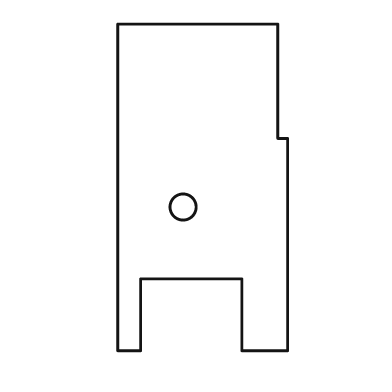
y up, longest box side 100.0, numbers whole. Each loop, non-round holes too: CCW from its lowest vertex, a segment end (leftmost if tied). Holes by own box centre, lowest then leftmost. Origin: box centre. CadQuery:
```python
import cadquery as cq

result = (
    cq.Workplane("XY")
    .moveTo(-26.0, -50.0)
    .lineTo(-19.0, -50.0)
    .lineTo(-19.0, -28.0)
    .lineTo(12.0, -28.0)
    .lineTo(12.0, -50.0)
    .lineTo(26.0, -50.0)
    .lineTo(26.0, 15.0)
    .lineTo(23.0, 15.0)
    .lineTo(23.0, 50.0)
    .lineTo(-26.0, 50.0)
    .close()
    .moveTo(-6.0, -6.0)
    .circle(4.0)
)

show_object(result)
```